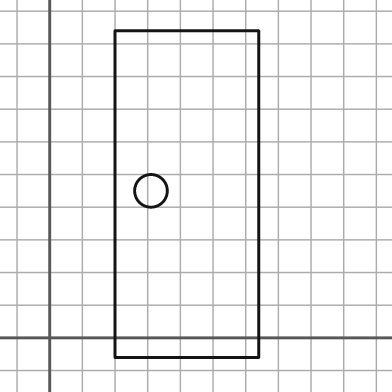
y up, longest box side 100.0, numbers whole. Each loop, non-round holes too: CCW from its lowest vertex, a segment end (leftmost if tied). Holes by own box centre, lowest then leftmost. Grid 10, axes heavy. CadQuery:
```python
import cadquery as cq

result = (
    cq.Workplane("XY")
    .moveTo(20.0, -6.0)
    .lineTo(64.0, -6.0)
    .lineTo(64.0, 94.0)
    .lineTo(20.0, 94.0)
    .close()
    .moveTo(31.0, 45.0)
    .circle(5.0)
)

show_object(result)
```